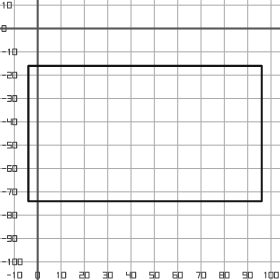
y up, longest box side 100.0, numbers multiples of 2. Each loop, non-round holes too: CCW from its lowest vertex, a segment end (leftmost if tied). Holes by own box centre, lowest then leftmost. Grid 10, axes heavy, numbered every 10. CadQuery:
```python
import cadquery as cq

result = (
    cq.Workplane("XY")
    .moveTo(-4.0, -74.0)
    .lineTo(96.0, -74.0)
    .lineTo(96.0, -16.0)
    .lineTo(-4.0, -16.0)
    .close()
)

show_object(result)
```